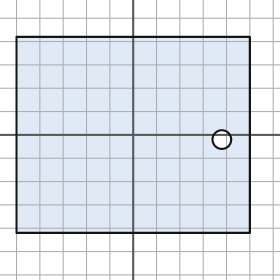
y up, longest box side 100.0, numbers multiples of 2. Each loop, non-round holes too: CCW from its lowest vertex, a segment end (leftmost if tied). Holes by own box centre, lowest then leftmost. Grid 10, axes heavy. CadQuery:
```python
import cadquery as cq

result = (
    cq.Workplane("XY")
    .moveTo(-50.0, -42.0)
    .lineTo(50.0, -42.0)
    .lineTo(50.0, 42.0)
    .lineTo(-50.0, 42.0)
    .close()
    .moveTo(38.0, -2.0)
    .circle(4.0)
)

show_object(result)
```